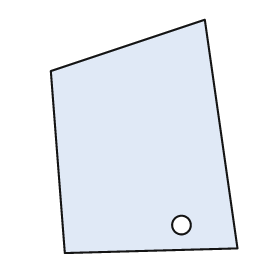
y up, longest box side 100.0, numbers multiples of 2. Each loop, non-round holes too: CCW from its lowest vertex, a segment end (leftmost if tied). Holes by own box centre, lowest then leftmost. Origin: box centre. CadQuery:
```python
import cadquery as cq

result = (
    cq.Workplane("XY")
    .moveTo(-34.0, -50.0)
    .lineTo(40.0, -48.0)
    .lineTo(26.0, 50.0)
    .lineTo(-40.0, 28.0)
    .close()
    .moveTo(16.0, -38.0)
    .circle(4.0)
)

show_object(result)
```